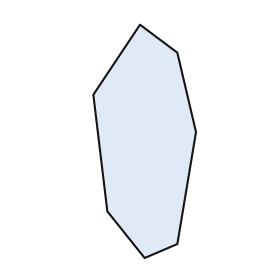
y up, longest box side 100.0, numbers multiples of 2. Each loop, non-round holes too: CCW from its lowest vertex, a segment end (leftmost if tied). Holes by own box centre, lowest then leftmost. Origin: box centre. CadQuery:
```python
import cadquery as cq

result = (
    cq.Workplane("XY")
    .moveTo(0.0, -50.0)
    .lineTo(14.0, -44.0)
    .lineTo(22.0, 4.0)
    .lineTo(14.0, 38.0)
    .lineTo(-2.0, 50.0)
    .lineTo(-22.0, 20.0)
    .lineTo(-16.0, -30.0)
    .close()
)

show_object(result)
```